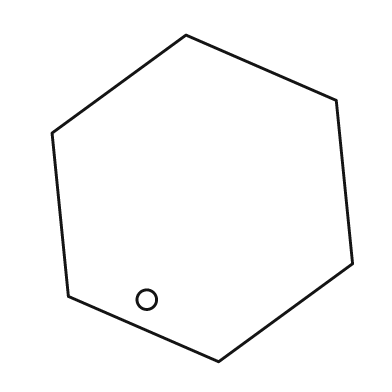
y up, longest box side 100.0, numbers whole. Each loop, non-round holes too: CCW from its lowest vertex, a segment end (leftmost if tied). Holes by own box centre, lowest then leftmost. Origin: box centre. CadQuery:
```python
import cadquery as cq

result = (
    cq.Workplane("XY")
    .moveTo(5.0, -50.0)
    .lineTo(46.0, -20.0)
    .lineTo(41.0, 30.0)
    .lineTo(-5.0, 50.0)
    .lineTo(-46.0, 20.0)
    .lineTo(-41.0, -30.0)
    .close()
    .moveTo(-17.0, -31.0)
    .circle(3.0)
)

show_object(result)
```